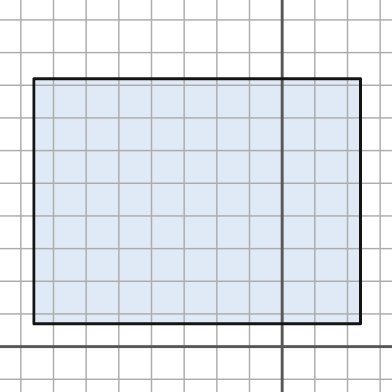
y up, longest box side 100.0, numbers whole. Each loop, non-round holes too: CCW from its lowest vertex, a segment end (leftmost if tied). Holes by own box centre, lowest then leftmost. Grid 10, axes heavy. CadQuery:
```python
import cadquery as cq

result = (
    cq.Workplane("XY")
    .moveTo(-76.0, 7.0)
    .lineTo(24.0, 7.0)
    .lineTo(24.0, 82.0)
    .lineTo(-76.0, 82.0)
    .close()
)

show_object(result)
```